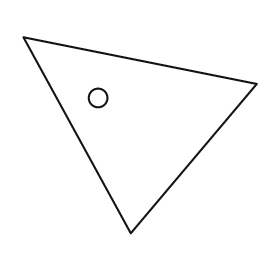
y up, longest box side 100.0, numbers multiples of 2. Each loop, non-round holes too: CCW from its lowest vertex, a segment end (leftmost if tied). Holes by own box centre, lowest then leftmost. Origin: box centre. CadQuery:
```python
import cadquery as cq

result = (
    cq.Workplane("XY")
    .moveTo(-4.0, -42.0)
    .lineTo(50.0, 22.0)
    .lineTo(-50.0, 42.0)
    .close()
    .moveTo(-18.0, 16.0)
    .circle(4.0)
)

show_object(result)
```